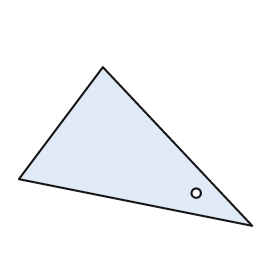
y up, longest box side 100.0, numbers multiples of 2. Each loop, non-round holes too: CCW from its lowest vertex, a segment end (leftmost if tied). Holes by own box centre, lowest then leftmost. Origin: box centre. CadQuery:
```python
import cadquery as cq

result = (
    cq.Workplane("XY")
    .moveTo(50.0, -34.0)
    .lineTo(-14.0, 34.0)
    .lineTo(-50.0, -14.0)
    .close()
    .moveTo(26.0, -20.0)
    .circle(2.0)
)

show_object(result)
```